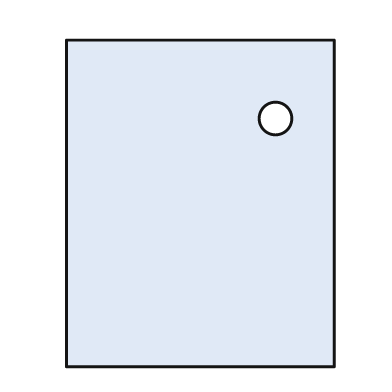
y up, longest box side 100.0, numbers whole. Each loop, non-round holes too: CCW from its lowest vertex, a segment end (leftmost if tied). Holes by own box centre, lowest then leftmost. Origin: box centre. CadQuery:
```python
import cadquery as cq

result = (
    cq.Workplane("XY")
    .moveTo(-41.0, -50.0)
    .lineTo(41.0, -50.0)
    .lineTo(41.0, 50.0)
    .lineTo(-41.0, 50.0)
    .close()
    .moveTo(23.0, 26.0)
    .circle(5.0)
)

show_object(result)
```